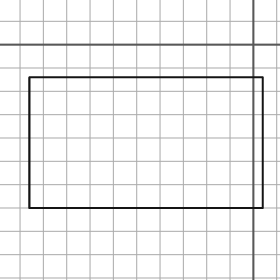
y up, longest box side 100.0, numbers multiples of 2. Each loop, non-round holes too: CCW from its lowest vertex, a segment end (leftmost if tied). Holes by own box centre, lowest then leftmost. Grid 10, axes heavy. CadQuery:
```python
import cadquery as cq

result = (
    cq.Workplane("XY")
    .moveTo(-96.0, -70.0)
    .lineTo(4.0, -70.0)
    .lineTo(4.0, -14.0)
    .lineTo(-96.0, -14.0)
    .close()
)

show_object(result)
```